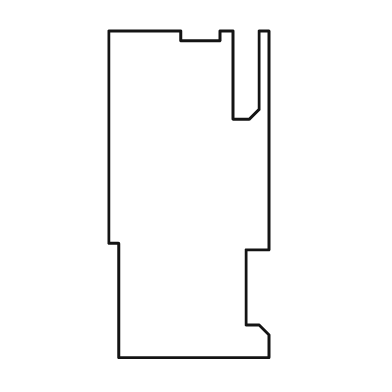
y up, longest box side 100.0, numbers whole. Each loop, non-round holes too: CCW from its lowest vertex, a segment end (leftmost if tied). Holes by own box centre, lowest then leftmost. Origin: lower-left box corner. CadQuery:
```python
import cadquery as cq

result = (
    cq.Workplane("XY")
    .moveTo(3.0, 0.0)
    .lineTo(49.0, 0.0)
    .lineTo(49.0, 7.0)
    .lineTo(46.0, 10.0)
    .lineTo(42.0, 10.0)
    .lineTo(42.0, 33.0)
    .lineTo(49.0, 33.0)
    .lineTo(49.0, 100.0)
    .lineTo(46.0, 100.0)
    .lineTo(46.0, 76.0)
    .lineTo(43.0, 73.0)
    .lineTo(38.0, 73.0)
    .lineTo(38.0, 100.0)
    .lineTo(34.0, 100.0)
    .lineTo(34.0, 97.0)
    .lineTo(22.0, 97.0)
    .lineTo(22.0, 100.0)
    .lineTo(0.0, 100.0)
    .lineTo(0.0, 35.0)
    .lineTo(3.0, 35.0)
    .close()
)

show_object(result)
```